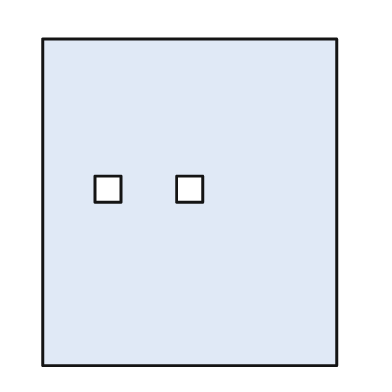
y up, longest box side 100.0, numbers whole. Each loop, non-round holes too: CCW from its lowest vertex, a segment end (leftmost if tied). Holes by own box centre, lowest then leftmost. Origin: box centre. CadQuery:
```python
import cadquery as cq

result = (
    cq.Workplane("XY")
    .moveTo(-45.0, -50.0)
    .lineTo(45.0, -50.0)
    .lineTo(45.0, 50.0)
    .lineTo(-45.0, 50.0)
    .close()
    .moveTo(-29.0, 0.0)
    .lineTo(-21.0, 0.0)
    .lineTo(-21.0, 8.0)
    .lineTo(-29.0, 8.0)
    .close()
    .moveTo(-4.0, 0.0)
    .lineTo(4.0, 0.0)
    .lineTo(4.0, 8.0)
    .lineTo(-4.0, 8.0)
    .close()
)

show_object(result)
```